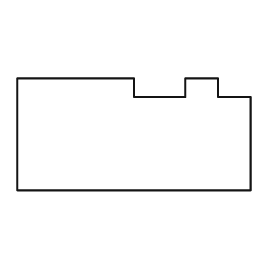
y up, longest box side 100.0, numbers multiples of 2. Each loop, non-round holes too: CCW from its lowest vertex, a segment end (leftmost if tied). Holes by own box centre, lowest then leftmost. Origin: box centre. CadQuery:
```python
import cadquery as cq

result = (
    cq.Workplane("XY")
    .moveTo(-50.0, -24.0)
    .lineTo(50.0, -24.0)
    .lineTo(50.0, 16.0)
    .lineTo(36.0, 16.0)
    .lineTo(36.0, 24.0)
    .lineTo(22.0, 24.0)
    .lineTo(22.0, 16.0)
    .lineTo(0.0, 16.0)
    .lineTo(0.0, 24.0)
    .lineTo(-50.0, 24.0)
    .close()
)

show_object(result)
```